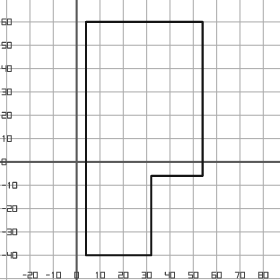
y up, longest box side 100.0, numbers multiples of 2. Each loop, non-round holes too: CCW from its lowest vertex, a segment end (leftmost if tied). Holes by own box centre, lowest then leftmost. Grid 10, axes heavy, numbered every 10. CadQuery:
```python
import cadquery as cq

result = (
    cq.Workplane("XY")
    .moveTo(4.0, -40.0)
    .lineTo(32.0, -40.0)
    .lineTo(32.0, -6.0)
    .lineTo(54.0, -6.0)
    .lineTo(54.0, 60.0)
    .lineTo(4.0, 60.0)
    .close()
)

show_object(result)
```